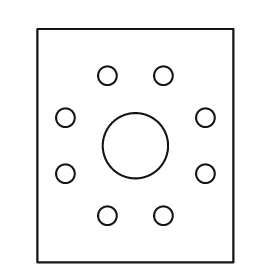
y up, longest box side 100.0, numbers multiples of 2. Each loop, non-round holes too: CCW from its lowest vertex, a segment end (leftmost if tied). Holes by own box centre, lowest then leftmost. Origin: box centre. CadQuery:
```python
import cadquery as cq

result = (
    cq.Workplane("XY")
    .moveTo(-42.0, -50.0)
    .lineTo(42.0, -50.0)
    .lineTo(42.0, 50.0)
    .lineTo(-42.0, 50.0)
    .close()
    .moveTo(-12.0, -30.0)
    .circle(4.0)
    .moveTo(12.0, -30.0)
    .circle(4.0)
    .moveTo(-30.0, -12.0)
    .circle(4.0)
    .moveTo(30.0, -12.0)
    .circle(4.0)
    .moveTo(0.0, 0.0)
    .circle(14.0)
    .moveTo(-30.0, 12.0)
    .circle(4.0)
    .moveTo(30.0, 12.0)
    .circle(4.0)
    .moveTo(-12.0, 30.0)
    .circle(4.0)
    .moveTo(12.0, 30.0)
    .circle(4.0)
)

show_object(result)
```